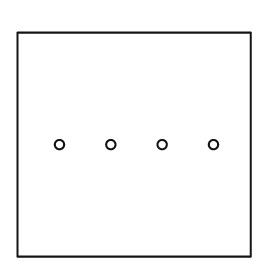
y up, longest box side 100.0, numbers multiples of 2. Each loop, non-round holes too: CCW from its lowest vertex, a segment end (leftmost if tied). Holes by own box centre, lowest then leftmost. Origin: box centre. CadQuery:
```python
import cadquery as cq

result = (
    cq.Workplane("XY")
    .moveTo(-50.0, -48.0)
    .lineTo(50.0, -48.0)
    .lineTo(50.0, 48.0)
    .lineTo(-50.0, 48.0)
    .close()
    .moveTo(-32.0, 0.0)
    .circle(2.0)
    .moveTo(-10.0, 0.0)
    .circle(2.0)
    .moveTo(12.0, 0.0)
    .circle(2.0)
    .moveTo(34.0, 0.0)
    .circle(2.0)
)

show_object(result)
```